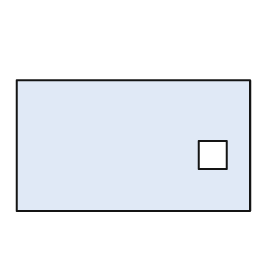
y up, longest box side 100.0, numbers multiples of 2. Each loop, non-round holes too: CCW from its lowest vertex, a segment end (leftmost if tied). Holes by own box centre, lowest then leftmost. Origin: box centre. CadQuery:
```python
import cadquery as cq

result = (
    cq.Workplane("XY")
    .moveTo(-50.0, -28.0)
    .lineTo(50.0, -28.0)
    .lineTo(50.0, 28.0)
    .lineTo(-50.0, 28.0)
    .close()
    .moveTo(28.0, -10.0)
    .lineTo(40.0, -10.0)
    .lineTo(40.0, 2.0)
    .lineTo(28.0, 2.0)
    .close()
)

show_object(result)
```